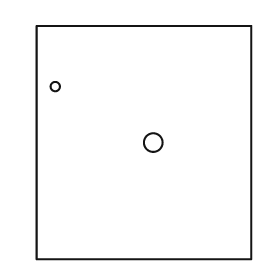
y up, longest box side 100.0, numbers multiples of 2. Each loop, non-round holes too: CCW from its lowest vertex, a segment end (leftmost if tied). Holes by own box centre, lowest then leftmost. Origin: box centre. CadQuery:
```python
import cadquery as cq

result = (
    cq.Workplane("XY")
    .moveTo(-46.0, -50.0)
    .lineTo(46.0, -50.0)
    .lineTo(46.0, 50.0)
    .lineTo(-46.0, 50.0)
    .close()
    .moveTo(4.0, 0.0)
    .circle(4.0)
    .moveTo(-38.0, 24.0)
    .circle(2.0)
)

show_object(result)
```